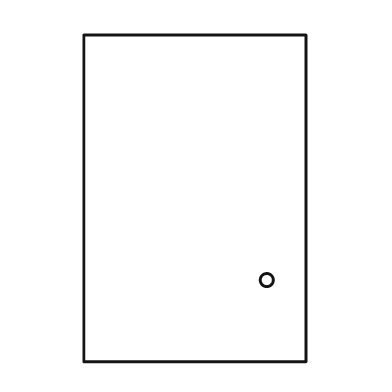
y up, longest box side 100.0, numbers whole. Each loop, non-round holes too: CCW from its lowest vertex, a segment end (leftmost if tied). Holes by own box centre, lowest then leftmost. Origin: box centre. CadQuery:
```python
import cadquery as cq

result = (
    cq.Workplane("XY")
    .moveTo(-34.0, -50.0)
    .lineTo(34.0, -50.0)
    .lineTo(34.0, 50.0)
    .lineTo(-34.0, 50.0)
    .close()
    .moveTo(22.0, -25.0)
    .circle(2.0)
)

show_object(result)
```